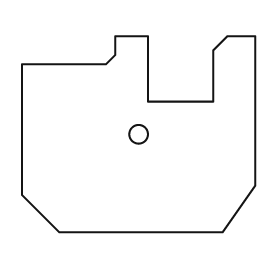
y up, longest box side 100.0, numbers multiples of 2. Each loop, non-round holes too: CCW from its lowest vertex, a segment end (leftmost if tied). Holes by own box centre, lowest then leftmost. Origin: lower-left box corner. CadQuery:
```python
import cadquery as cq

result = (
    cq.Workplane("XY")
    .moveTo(16.0, 0.0)
    .lineTo(86.0, 0.0)
    .lineTo(100.0, 20.0)
    .lineTo(100.0, 84.0)
    .lineTo(88.0, 84.0)
    .lineTo(82.0, 78.0)
    .lineTo(82.0, 56.0)
    .lineTo(54.0, 56.0)
    .lineTo(54.0, 84.0)
    .lineTo(40.0, 84.0)
    .lineTo(40.0, 76.0)
    .lineTo(36.0, 72.0)
    .lineTo(0.0, 72.0)
    .lineTo(0.0, 16.0)
    .close()
    .moveTo(50.0, 42.0)
    .circle(4.0)
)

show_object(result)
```